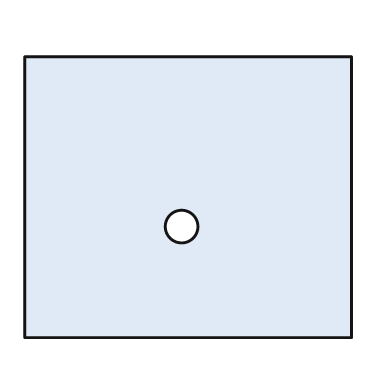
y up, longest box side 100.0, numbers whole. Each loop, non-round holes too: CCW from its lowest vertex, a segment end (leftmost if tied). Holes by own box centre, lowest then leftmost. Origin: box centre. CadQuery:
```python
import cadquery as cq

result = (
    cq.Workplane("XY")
    .moveTo(-50.0, -43.0)
    .lineTo(50.0, -43.0)
    .lineTo(50.0, 43.0)
    .lineTo(-50.0, 43.0)
    .close()
    .moveTo(-2.0, -9.0)
    .circle(5.0)
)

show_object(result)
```